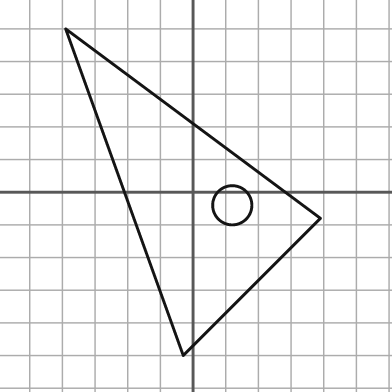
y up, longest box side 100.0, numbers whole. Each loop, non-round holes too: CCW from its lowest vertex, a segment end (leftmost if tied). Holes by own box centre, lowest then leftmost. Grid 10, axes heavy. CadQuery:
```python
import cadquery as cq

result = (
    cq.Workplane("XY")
    .moveTo(-3.0, -50.0)
    .lineTo(39.0, -8.0)
    .lineTo(-39.0, 50.0)
    .close()
    .moveTo(12.0, -4.0)
    .circle(6.0)
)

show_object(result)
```